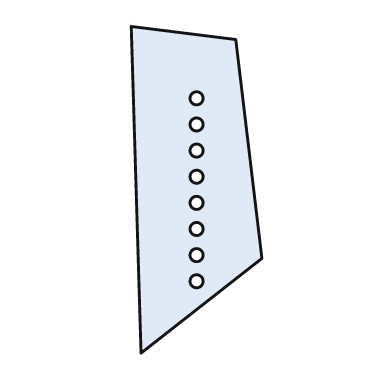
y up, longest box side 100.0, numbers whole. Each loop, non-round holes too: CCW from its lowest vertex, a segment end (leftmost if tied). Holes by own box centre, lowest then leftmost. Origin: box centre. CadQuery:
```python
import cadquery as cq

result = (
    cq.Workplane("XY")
    .moveTo(-17.0, -50.0)
    .lineTo(20.0, -21.0)
    .lineTo(12.0, 46.0)
    .lineTo(-20.0, 50.0)
    .close()
    .moveTo(0.0, -28.0)
    .circle(2.0)
    .moveTo(0.0, -20.0)
    .circle(2.0)
    .moveTo(0.0, -12.0)
    .circle(2.0)
    .moveTo(0.0, -4.0)
    .circle(2.0)
    .moveTo(0.0, 4.0)
    .circle(2.0)
    .moveTo(0.0, 12.0)
    .circle(2.0)
    .moveTo(0.0, 20.0)
    .circle(2.0)
    .moveTo(0.0, 28.0)
    .circle(2.0)
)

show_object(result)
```